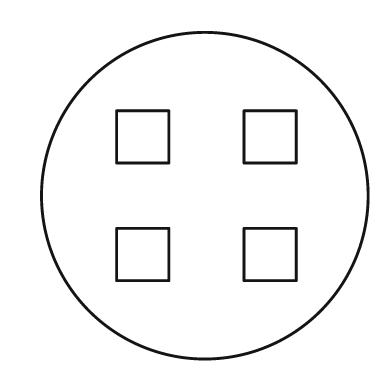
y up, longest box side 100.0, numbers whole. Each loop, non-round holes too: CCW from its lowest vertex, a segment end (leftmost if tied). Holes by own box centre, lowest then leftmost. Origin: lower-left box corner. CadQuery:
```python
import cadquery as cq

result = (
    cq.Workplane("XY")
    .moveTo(50.0, 50.0)
    .circle(50.0)
    .moveTo(23.0, 24.0)
    .lineTo(39.0, 24.0)
    .lineTo(39.0, 40.0)
    .lineTo(23.0, 40.0)
    .close()
    .moveTo(62.0, 24.0)
    .lineTo(78.0, 24.0)
    .lineTo(78.0, 40.0)
    .lineTo(62.0, 40.0)
    .close()
    .moveTo(23.0, 60.0)
    .lineTo(39.0, 60.0)
    .lineTo(39.0, 76.0)
    .lineTo(23.0, 76.0)
    .close()
    .moveTo(62.0, 60.0)
    .lineTo(78.0, 60.0)
    .lineTo(78.0, 76.0)
    .lineTo(62.0, 76.0)
    .close()
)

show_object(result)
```